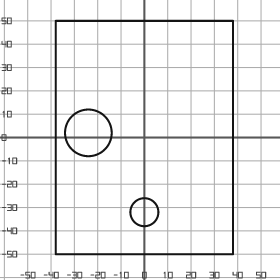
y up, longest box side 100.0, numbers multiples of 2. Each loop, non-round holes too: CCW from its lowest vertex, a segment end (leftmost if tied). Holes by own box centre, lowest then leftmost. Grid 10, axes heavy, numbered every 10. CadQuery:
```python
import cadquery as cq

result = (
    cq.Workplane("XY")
    .moveTo(-38.0, -50.0)
    .lineTo(38.0, -50.0)
    .lineTo(38.0, 50.0)
    .lineTo(-38.0, 50.0)
    .close()
    .moveTo(0.0, -32.0)
    .circle(6.0)
    .moveTo(-24.0, 2.0)
    .circle(10.0)
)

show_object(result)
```